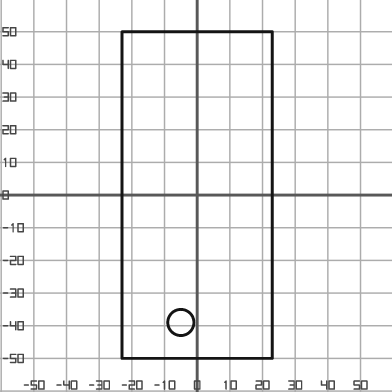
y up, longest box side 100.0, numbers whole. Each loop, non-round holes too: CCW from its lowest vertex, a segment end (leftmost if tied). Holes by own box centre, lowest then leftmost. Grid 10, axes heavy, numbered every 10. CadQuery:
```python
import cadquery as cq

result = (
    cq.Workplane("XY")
    .moveTo(-23.0, -50.0)
    .lineTo(23.0, -50.0)
    .lineTo(23.0, 50.0)
    .lineTo(-23.0, 50.0)
    .close()
    .moveTo(-5.0, -39.0)
    .circle(4.0)
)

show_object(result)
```